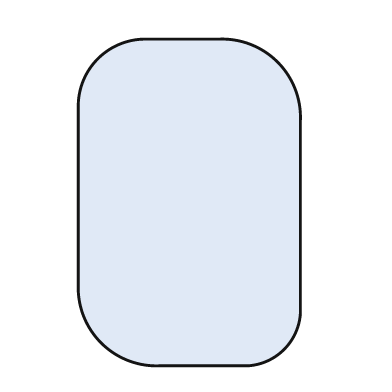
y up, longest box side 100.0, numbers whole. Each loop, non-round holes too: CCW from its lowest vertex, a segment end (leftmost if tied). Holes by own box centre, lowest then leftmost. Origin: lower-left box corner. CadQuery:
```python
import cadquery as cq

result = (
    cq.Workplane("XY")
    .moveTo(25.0, 0.0)
    .lineTo(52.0, 0.0)
    .threePointArc((63.0, 5.0), (68.0, 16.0))
    .lineTo(68.0, 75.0)
    .threePointArc((61.0, 93.0), (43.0, 100.0))
    .lineTo(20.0, 100.0)
    .threePointArc((6.0, 94.0), (0.0, 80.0))
    .lineTo(0.0, 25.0)
    .threePointArc((7.0, 7.0), (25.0, 0.0))
    .close()
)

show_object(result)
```